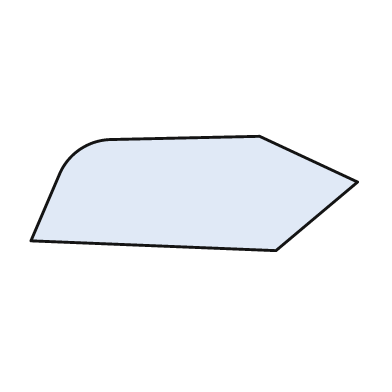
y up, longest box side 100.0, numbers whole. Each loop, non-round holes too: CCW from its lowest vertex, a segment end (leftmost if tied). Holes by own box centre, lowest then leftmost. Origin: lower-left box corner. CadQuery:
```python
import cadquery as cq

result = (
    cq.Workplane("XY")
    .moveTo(75.0, 0.0)
    .lineTo(100.0, 21.0)
    .lineTo(70.0, 35.0)
    .lineTo(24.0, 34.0)
    .threePointArc((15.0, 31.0), (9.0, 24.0))
    .lineTo(0.0, 3.0)
    .close()
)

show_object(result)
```